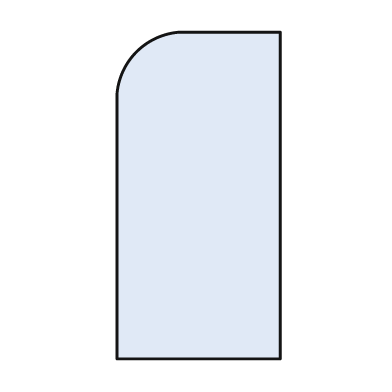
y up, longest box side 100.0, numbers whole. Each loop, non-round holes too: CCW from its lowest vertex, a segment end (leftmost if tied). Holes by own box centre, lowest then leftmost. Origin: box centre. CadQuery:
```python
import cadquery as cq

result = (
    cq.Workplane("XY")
    .moveTo(-25.0, -50.0)
    .lineTo(25.0, -50.0)
    .lineTo(25.0, 50.0)
    .lineTo(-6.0, 50.0)
    .threePointArc((-19.0, 44.0), (-25.0, 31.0))
    .close()
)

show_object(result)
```